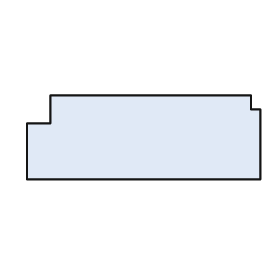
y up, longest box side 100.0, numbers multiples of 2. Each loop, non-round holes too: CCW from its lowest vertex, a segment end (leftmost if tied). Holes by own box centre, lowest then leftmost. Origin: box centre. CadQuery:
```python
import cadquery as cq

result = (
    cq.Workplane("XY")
    .moveTo(-50.0, -18.0)
    .lineTo(50.0, -18.0)
    .lineTo(50.0, 12.0)
    .lineTo(46.0, 12.0)
    .lineTo(46.0, 18.0)
    .lineTo(-40.0, 18.0)
    .lineTo(-40.0, 6.0)
    .lineTo(-50.0, 6.0)
    .close()
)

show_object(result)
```